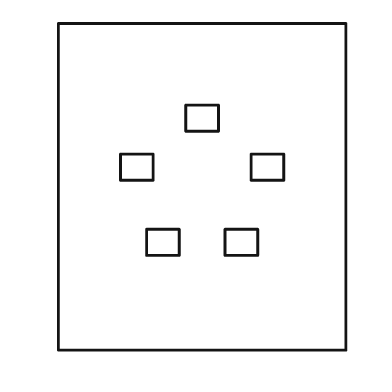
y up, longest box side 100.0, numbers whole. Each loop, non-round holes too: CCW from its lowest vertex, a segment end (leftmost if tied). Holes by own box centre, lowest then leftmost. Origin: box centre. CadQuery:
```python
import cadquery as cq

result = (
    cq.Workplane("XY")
    .moveTo(-44.0, -50.0)
    .lineTo(44.0, -50.0)
    .lineTo(44.0, 50.0)
    .lineTo(-44.0, 50.0)
    .close()
    .moveTo(-17.0, -21.0)
    .lineTo(-7.0, -21.0)
    .lineTo(-7.0, -13.0)
    .lineTo(-17.0, -13.0)
    .close()
    .moveTo(7.0, -21.0)
    .lineTo(17.0, -21.0)
    .lineTo(17.0, -13.0)
    .lineTo(7.0, -13.0)
    .close()
    .moveTo(-25.0, 2.0)
    .lineTo(-15.0, 2.0)
    .lineTo(-15.0, 10.0)
    .lineTo(-25.0, 10.0)
    .close()
    .moveTo(15.0, 2.0)
    .lineTo(25.0, 2.0)
    .lineTo(25.0, 10.0)
    .lineTo(15.0, 10.0)
    .close()
    .moveTo(-5.0, 17.0)
    .lineTo(5.0, 17.0)
    .lineTo(5.0, 25.0)
    .lineTo(-5.0, 25.0)
    .close()
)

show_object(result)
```